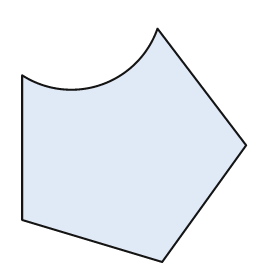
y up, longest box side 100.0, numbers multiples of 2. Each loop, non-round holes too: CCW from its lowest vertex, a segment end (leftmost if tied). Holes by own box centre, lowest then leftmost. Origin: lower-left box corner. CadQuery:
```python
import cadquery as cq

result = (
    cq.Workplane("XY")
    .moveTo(60.0, 0.0)
    .lineTo(96.0, 50.0)
    .lineTo(58.0, 100.0)
    .threePointArc((34.0, 76.0), (0.0, 80.0))
    .lineTo(0.0, 18.0)
    .close()
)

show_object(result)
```